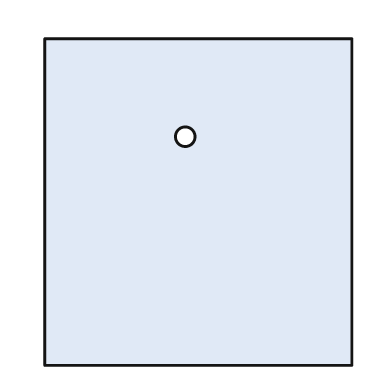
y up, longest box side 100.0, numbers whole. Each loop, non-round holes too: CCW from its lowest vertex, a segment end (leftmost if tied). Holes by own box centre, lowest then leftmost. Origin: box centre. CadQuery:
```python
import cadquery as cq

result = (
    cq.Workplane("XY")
    .moveTo(-47.0, -50.0)
    .lineTo(47.0, -50.0)
    .lineTo(47.0, 50.0)
    .lineTo(-47.0, 50.0)
    .close()
    .moveTo(-4.0, 20.0)
    .circle(3.0)
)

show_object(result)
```